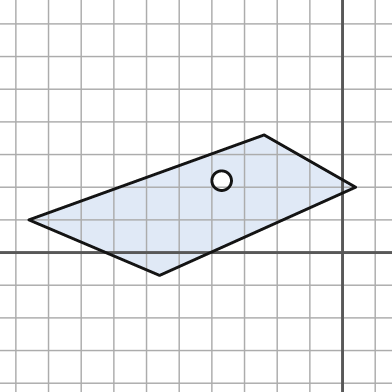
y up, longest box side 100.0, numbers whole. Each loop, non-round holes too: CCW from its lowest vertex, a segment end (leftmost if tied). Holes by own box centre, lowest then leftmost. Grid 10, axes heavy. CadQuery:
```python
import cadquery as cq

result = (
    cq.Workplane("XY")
    .moveTo(-56.0, -7.0)
    .lineTo(4.0, 20.0)
    .lineTo(-24.0, 36.0)
    .lineTo(-96.0, 10.0)
    .close()
    .moveTo(-37.0, 22.0)
    .circle(3.0)
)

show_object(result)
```